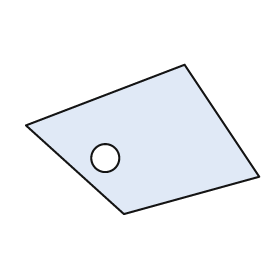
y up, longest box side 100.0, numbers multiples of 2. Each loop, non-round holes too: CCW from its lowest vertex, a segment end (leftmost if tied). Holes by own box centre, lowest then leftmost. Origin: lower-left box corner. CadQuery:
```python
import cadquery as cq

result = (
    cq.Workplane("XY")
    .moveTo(42.0, 0.0)
    .lineTo(100.0, 16.0)
    .lineTo(68.0, 64.0)
    .lineTo(0.0, 38.0)
    .close()
    .moveTo(34.0, 24.0)
    .circle(6.0)
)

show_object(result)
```